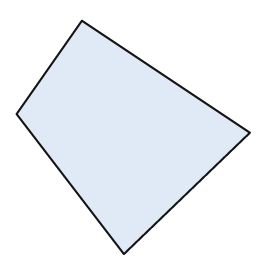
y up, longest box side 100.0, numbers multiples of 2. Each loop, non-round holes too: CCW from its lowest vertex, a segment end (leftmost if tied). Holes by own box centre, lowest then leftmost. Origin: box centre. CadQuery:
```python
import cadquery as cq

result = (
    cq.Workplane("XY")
    .moveTo(-4.0, -50.0)
    .lineTo(50.0, 2.0)
    .lineTo(-22.0, 50.0)
    .lineTo(-50.0, 10.0)
    .close()
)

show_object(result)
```